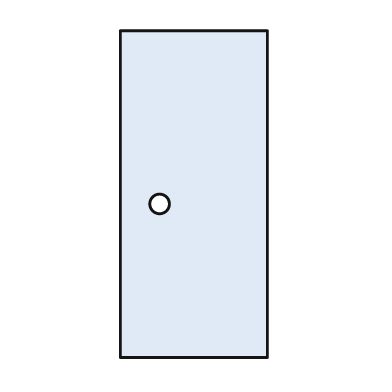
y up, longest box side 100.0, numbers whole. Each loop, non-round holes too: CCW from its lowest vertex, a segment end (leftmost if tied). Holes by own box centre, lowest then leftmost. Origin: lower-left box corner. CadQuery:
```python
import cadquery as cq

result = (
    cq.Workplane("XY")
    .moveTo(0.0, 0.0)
    .lineTo(45.0, 0.0)
    .lineTo(45.0, 100.0)
    .lineTo(0.0, 100.0)
    .close()
    .moveTo(12.0, 47.0)
    .circle(3.0)
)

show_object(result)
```